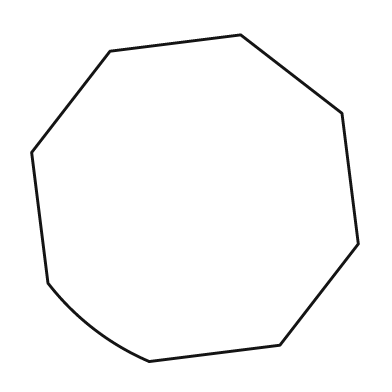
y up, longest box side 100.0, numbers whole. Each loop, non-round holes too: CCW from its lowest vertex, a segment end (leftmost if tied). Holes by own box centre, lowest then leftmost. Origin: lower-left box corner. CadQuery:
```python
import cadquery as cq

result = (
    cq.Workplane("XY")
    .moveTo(36.0, 0.0)
    .lineTo(76.0, 5.0)
    .lineTo(100.0, 36.0)
    .lineTo(95.0, 76.0)
    .lineTo(64.0, 100.0)
    .lineTo(24.0, 95.0)
    .lineTo(0.0, 64.0)
    .lineTo(5.0, 24.0)
    .threePointArc((19.0, 10.0), (36.0, 0.0))
    .close()
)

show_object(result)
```